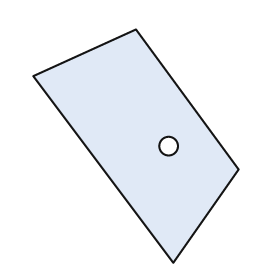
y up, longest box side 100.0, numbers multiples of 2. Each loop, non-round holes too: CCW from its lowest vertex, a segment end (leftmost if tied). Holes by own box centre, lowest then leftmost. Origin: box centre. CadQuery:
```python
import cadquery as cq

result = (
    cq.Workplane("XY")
    .moveTo(16.0, -50.0)
    .lineTo(44.0, -10.0)
    .lineTo(0.0, 50.0)
    .lineTo(-44.0, 30.0)
    .close()
    .moveTo(14.0, 0.0)
    .circle(4.0)
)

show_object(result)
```